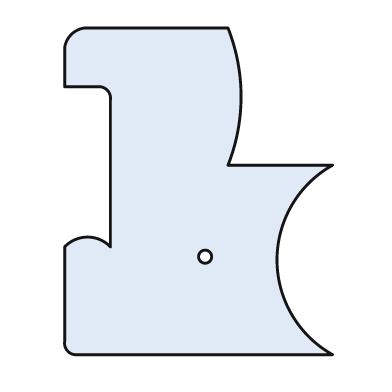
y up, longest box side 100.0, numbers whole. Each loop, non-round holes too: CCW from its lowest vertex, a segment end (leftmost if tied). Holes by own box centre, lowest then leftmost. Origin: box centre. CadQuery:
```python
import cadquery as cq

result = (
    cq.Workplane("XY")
    .moveTo(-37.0, -50.0)
    .lineTo(41.0, -50.0)
    .threePointArc((24.0, -21.0), (41.0, 8.0))
    .lineTo(9.0, 8.0)
    .threePointArc((13.0, 29.0), (9.0, 50.0))
    .lineTo(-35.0, 50.0)
    .threePointArc((-39.0, 48.0), (-41.0, 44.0))
    .lineTo(-41.0, 32.0)
    .lineTo(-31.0, 32.0)
    .threePointArc((-28.0, 31.0), (-27.0, 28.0))
    .lineTo(-27.0, -17.0)
    .threePointArc((-34.0, -14.0), (-41.0, -17.0))
    .lineTo(-41.0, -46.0)
    .threePointArc((-40.0, -49.0), (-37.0, -50.0))
    .close()
    .moveTo(2.0, -20.0)
    .circle(2.0)
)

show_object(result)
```